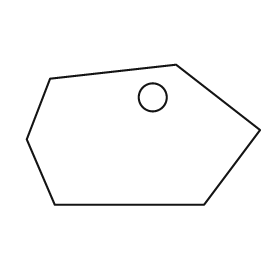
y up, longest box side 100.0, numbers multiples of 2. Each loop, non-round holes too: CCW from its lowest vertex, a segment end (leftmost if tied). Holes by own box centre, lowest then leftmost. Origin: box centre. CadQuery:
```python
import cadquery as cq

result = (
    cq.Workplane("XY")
    .moveTo(-38.0, -30.0)
    .lineTo(26.0, -30.0)
    .lineTo(50.0, 2.0)
    .lineTo(14.0, 30.0)
    .lineTo(-40.0, 24.0)
    .lineTo(-50.0, -2.0)
    .close()
    .moveTo(4.0, 16.0)
    .circle(6.0)
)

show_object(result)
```